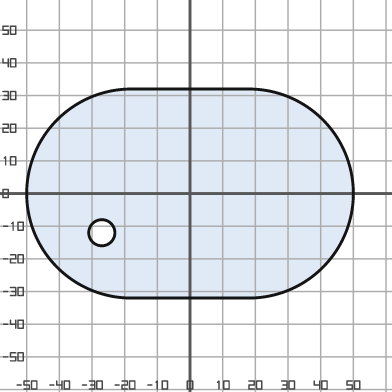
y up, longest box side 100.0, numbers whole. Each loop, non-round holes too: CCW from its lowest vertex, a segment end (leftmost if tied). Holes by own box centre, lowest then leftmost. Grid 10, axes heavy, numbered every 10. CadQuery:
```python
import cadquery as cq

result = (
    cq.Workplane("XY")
    .moveTo(-18.0, -32.0)
    .lineTo(18.0, -32.0)
    .threePointArc((50.0, 0.0), (18.0, 32.0))
    .lineTo(-18.0, 32.0)
    .threePointArc((-50.0, 0.0), (-18.0, -32.0))
    .close()
    .moveTo(-27.0, -12.0)
    .circle(4.0)
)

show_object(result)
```